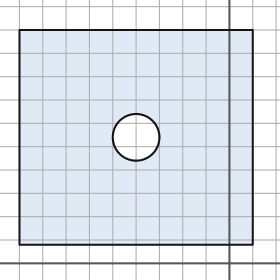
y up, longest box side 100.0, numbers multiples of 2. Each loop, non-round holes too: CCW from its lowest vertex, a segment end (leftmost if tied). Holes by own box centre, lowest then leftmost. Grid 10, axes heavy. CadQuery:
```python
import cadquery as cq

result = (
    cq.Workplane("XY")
    .moveTo(-90.0, 8.0)
    .lineTo(10.0, 8.0)
    .lineTo(10.0, 100.0)
    .lineTo(-90.0, 100.0)
    .close()
    .moveTo(-40.0, 54.0)
    .circle(10.0)
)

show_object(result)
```